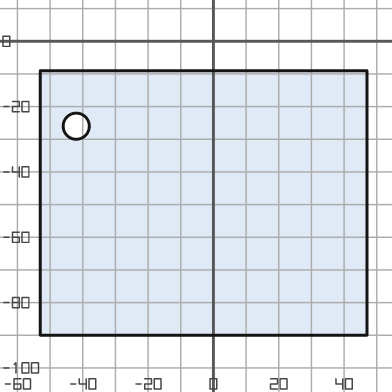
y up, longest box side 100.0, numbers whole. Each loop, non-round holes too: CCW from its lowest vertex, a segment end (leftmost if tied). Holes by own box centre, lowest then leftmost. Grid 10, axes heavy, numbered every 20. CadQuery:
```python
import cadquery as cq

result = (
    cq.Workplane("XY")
    .moveTo(-53.0, -90.0)
    .lineTo(47.0, -90.0)
    .lineTo(47.0, -9.0)
    .lineTo(-53.0, -9.0)
    .close()
    .moveTo(-42.0, -26.0)
    .circle(4.0)
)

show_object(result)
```